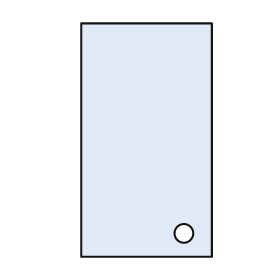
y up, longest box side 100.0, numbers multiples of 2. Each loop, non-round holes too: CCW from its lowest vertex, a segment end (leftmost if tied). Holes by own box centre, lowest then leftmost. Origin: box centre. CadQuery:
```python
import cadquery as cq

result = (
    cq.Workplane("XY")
    .moveTo(-28.0, -50.0)
    .lineTo(28.0, -50.0)
    .lineTo(28.0, 50.0)
    .lineTo(-28.0, 50.0)
    .close()
    .moveTo(16.0, -40.0)
    .circle(4.0)
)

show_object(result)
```